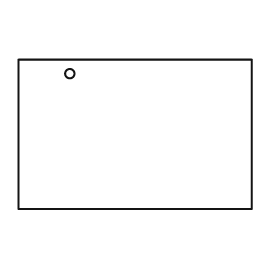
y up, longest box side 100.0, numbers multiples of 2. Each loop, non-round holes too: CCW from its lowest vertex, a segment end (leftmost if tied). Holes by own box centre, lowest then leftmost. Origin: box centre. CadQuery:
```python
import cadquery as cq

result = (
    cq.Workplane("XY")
    .moveTo(-50.0, -32.0)
    .lineTo(50.0, -32.0)
    .lineTo(50.0, 32.0)
    .lineTo(-50.0, 32.0)
    .close()
    .moveTo(-28.0, 26.0)
    .circle(2.0)
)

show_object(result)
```